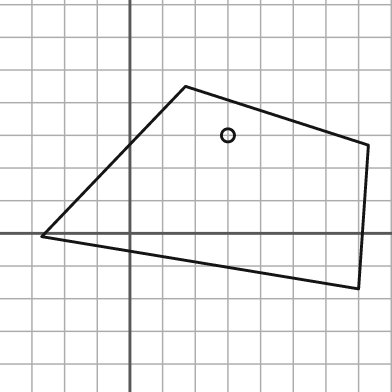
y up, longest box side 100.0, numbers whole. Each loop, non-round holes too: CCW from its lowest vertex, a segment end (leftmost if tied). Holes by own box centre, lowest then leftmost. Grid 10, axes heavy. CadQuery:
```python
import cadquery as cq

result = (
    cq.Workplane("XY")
    .moveTo(70.0, -17.0)
    .lineTo(73.0, 27.0)
    .lineTo(17.0, 45.0)
    .lineTo(-27.0, -1.0)
    .close()
    .moveTo(30.0, 30.0)
    .circle(2.0)
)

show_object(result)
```